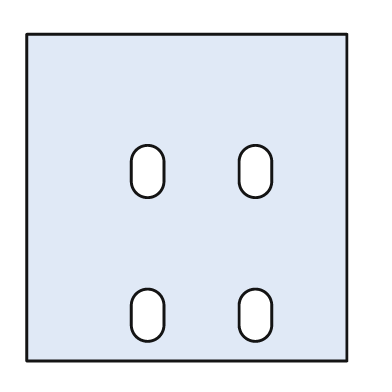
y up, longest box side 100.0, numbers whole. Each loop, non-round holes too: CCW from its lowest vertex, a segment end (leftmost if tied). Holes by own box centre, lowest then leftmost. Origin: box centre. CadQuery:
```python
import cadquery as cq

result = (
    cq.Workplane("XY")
    .moveTo(-49.0, -50.0)
    .lineTo(49.0, -50.0)
    .lineTo(49.0, 50.0)
    .lineTo(-49.0, 50.0)
    .close()
    .moveTo(-17.0, -39.0)
    .threePointArc((-12.0, -44.0), (-7.0, -39.0))
    .lineTo(-7.0, -33.0)
    .threePointArc((-12.0, -28.0), (-17.0, -33.0))
    .close()
    .moveTo(16.0, -39.0)
    .threePointArc((21.0, -44.0), (26.0, -39.0))
    .lineTo(26.0, -33.0)
    .threePointArc((21.0, -28.0), (16.0, -33.0))
    .close()
    .moveTo(-17.0, 5.0)
    .threePointArc((-12.0, 0.0), (-7.0, 5.0))
    .lineTo(-7.0, 11.0)
    .threePointArc((-12.0, 16.0), (-17.0, 11.0))
    .close()
    .moveTo(16.0, 5.0)
    .threePointArc((21.0, 0.0), (26.0, 5.0))
    .lineTo(26.0, 11.0)
    .threePointArc((21.0, 16.0), (16.0, 11.0))
    .close()
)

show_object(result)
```